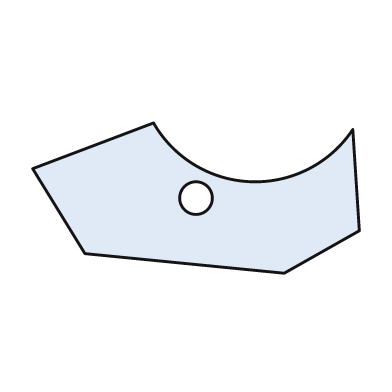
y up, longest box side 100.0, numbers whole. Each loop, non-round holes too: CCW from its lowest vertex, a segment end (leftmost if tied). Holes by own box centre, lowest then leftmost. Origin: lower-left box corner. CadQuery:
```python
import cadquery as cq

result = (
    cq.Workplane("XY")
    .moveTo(77.0, 0.0)
    .lineTo(100.0, 13.0)
    .lineTo(98.0, 44.0)
    .threePointArc((67.0, 28.0), (37.0, 46.0))
    .lineTo(0.0, 32.0)
    .lineTo(16.0, 6.0)
    .close()
    .moveTo(50.0, 23.0)
    .circle(5.0)
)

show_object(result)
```